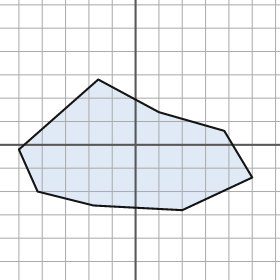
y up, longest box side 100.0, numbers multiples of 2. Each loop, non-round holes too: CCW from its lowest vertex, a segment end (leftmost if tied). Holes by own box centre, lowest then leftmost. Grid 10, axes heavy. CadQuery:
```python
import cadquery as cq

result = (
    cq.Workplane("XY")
    .moveTo(20.0, -28.0)
    .lineTo(50.0, -14.0)
    .lineTo(38.0, 6.0)
    .lineTo(10.0, 14.0)
    .lineTo(-16.0, 28.0)
    .lineTo(-50.0, -2.0)
    .lineTo(-42.0, -20.0)
    .lineTo(-18.0, -26.0)
    .close()
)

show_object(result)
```